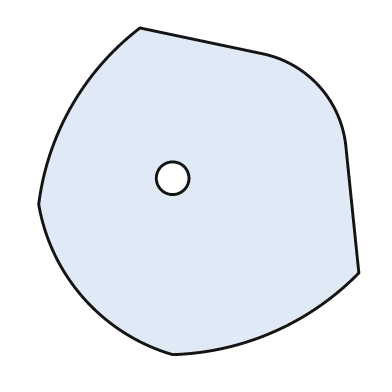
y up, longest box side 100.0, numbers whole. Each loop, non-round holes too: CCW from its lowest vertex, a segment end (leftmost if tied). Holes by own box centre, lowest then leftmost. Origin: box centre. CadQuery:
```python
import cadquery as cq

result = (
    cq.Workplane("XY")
    .moveTo(-8.0, -50.0)
    .threePointArc((23.0, -43.0), (49.0, -25.0))
    .lineTo(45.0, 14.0)
    .threePointArc((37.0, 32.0), (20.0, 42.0))
    .lineTo(-18.0, 50.0)
    .threePointArc((-39.0, 26.0), (-49.0, -4.0))
    .threePointArc((-35.0, -33.0), (-8.0, -50.0))
    .close()
    .moveTo(-8.0, 4.0)
    .circle(5.0)
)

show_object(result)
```